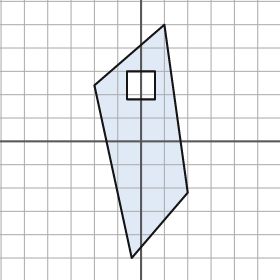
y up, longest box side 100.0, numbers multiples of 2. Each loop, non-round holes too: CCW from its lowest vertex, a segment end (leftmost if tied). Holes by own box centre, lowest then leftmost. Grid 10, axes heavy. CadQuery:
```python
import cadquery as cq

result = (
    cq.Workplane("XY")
    .moveTo(-4.0, -50.0)
    .lineTo(20.0, -22.0)
    .lineTo(10.0, 50.0)
    .lineTo(-20.0, 24.0)
    .close()
    .moveTo(-6.0, 18.0)
    .lineTo(6.0, 18.0)
    .lineTo(6.0, 30.0)
    .lineTo(-6.0, 30.0)
    .close()
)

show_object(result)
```